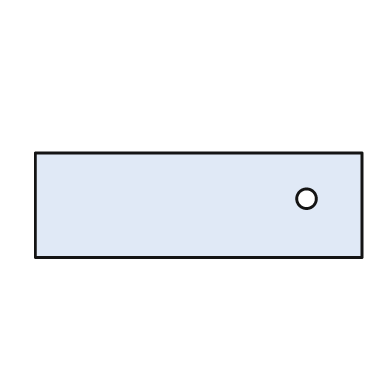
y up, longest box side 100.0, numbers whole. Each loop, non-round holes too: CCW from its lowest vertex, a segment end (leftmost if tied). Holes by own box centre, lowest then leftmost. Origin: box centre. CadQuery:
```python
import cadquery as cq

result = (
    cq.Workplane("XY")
    .moveTo(-50.0, -16.0)
    .lineTo(50.0, -16.0)
    .lineTo(50.0, 16.0)
    .lineTo(-50.0, 16.0)
    .close()
    .moveTo(33.0, 2.0)
    .circle(3.0)
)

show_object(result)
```